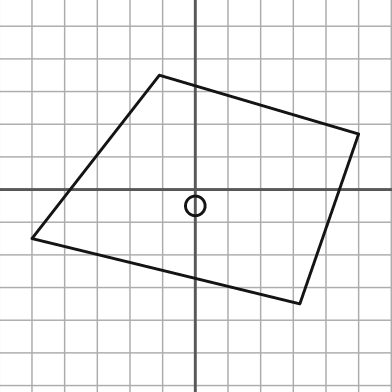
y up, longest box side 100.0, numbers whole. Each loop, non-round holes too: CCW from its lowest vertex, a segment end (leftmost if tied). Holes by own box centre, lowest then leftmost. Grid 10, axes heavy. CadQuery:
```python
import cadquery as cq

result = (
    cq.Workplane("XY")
    .moveTo(32.0, -35.0)
    .lineTo(50.0, 17.0)
    .lineTo(-11.0, 35.0)
    .lineTo(-50.0, -15.0)
    .close()
    .moveTo(0.0, -5.0)
    .circle(3.0)
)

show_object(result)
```